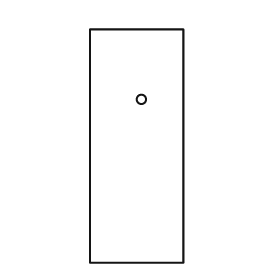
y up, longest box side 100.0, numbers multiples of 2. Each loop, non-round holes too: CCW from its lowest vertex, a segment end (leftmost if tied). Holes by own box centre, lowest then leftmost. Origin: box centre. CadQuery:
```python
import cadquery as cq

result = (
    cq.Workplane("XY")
    .moveTo(-20.0, -50.0)
    .lineTo(20.0, -50.0)
    .lineTo(20.0, 50.0)
    .lineTo(-20.0, 50.0)
    .close()
    .moveTo(2.0, 20.0)
    .circle(2.0)
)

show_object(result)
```